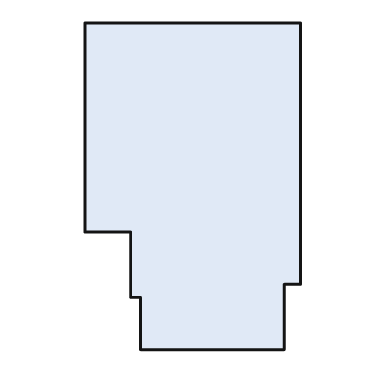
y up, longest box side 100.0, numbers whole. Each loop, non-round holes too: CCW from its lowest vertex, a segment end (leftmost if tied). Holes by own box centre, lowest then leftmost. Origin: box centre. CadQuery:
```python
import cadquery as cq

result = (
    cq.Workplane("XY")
    .moveTo(-16.0, -50.0)
    .lineTo(28.0, -50.0)
    .lineTo(28.0, -30.0)
    .lineTo(33.0, -30.0)
    .lineTo(33.0, 50.0)
    .lineTo(-33.0, 50.0)
    .lineTo(-33.0, -14.0)
    .lineTo(-19.0, -14.0)
    .lineTo(-19.0, -34.0)
    .lineTo(-16.0, -34.0)
    .close()
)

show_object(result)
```